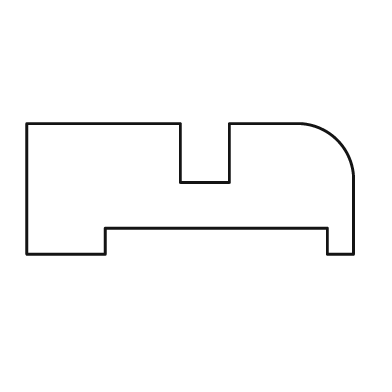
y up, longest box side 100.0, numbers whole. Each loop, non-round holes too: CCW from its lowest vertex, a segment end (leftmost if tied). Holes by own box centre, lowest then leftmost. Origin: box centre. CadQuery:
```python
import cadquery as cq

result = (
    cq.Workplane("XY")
    .moveTo(-50.0, -20.0)
    .lineTo(-26.0, -20.0)
    .lineTo(-26.0, -12.0)
    .lineTo(42.0, -12.0)
    .lineTo(42.0, -20.0)
    .lineTo(50.0, -20.0)
    .lineTo(50.0, 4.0)
    .threePointArc((45.0, 15.0), (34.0, 20.0))
    .lineTo(12.0, 20.0)
    .lineTo(12.0, 2.0)
    .lineTo(-3.0, 2.0)
    .lineTo(-3.0, 20.0)
    .lineTo(-50.0, 20.0)
    .close()
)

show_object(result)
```